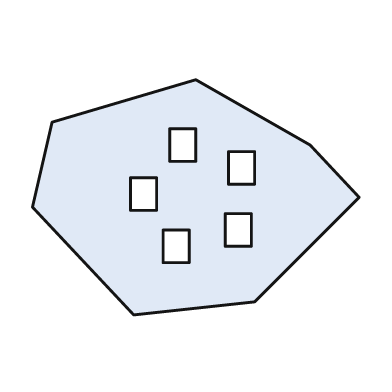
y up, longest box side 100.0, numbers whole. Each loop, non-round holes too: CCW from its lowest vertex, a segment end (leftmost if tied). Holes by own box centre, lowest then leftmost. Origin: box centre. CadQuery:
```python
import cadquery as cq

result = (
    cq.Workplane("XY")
    .moveTo(-19.0, -36.0)
    .lineTo(18.0, -32.0)
    .lineTo(50.0, 0.0)
    .lineTo(35.0, 16.0)
    .lineTo(0.0, 36.0)
    .lineTo(-44.0, 23.0)
    .lineTo(-50.0, -3.0)
    .close()
    .moveTo(-10.0, -20.0)
    .lineTo(-2.0, -20.0)
    .lineTo(-2.0, -10.0)
    .lineTo(-10.0, -10.0)
    .close()
    .moveTo(9.0, -15.0)
    .lineTo(17.0, -15.0)
    .lineTo(17.0, -5.0)
    .lineTo(9.0, -5.0)
    .close()
    .moveTo(-20.0, -4.0)
    .lineTo(-12.0, -4.0)
    .lineTo(-12.0, 6.0)
    .lineTo(-20.0, 6.0)
    .close()
    .moveTo(10.0, 4.0)
    .lineTo(18.0, 4.0)
    .lineTo(18.0, 14.0)
    .lineTo(10.0, 14.0)
    .close()
    .moveTo(-8.0, 11.0)
    .lineTo(0.0, 11.0)
    .lineTo(0.0, 21.0)
    .lineTo(-8.0, 21.0)
    .close()
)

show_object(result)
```